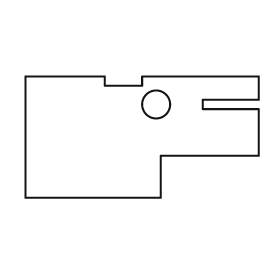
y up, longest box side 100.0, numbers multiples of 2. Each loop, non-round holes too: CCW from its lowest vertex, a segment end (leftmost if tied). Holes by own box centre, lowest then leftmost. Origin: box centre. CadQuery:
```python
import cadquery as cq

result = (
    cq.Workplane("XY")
    .moveTo(-50.0, -26.0)
    .lineTo(8.0, -26.0)
    .lineTo(8.0, -8.0)
    .lineTo(50.0, -8.0)
    .lineTo(50.0, 12.0)
    .lineTo(26.0, 12.0)
    .lineTo(26.0, 16.0)
    .lineTo(50.0, 16.0)
    .lineTo(50.0, 26.0)
    .lineTo(0.0, 26.0)
    .lineTo(0.0, 22.0)
    .lineTo(-16.0, 22.0)
    .lineTo(-16.0, 26.0)
    .lineTo(-50.0, 26.0)
    .close()
    .moveTo(6.0, 14.0)
    .circle(6.0)
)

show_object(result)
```